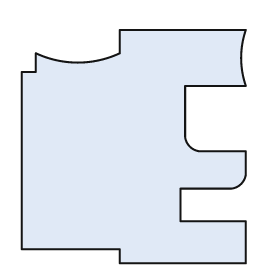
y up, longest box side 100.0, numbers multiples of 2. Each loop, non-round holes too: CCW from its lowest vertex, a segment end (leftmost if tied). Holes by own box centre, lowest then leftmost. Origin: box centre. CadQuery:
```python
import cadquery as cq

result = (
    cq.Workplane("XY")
    .moveTo(-6.0, -50.0)
    .lineTo(48.0, -50.0)
    .lineTo(48.0, -32.0)
    .lineTo(20.0, -32.0)
    .lineTo(20.0, -18.0)
    .lineTo(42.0, -18.0)
    .threePointArc((46.0, -16.0), (48.0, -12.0))
    .lineTo(48.0, -2.0)
    .lineTo(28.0, -2.0)
    .threePointArc((24.0, 0.0), (22.0, 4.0))
    .lineTo(22.0, 26.0)
    .lineTo(48.0, 26.0)
    .threePointArc((46.0, 38.0), (48.0, 50.0))
    .lineTo(-6.0, 50.0)
    .lineTo(-6.0, 40.0)
    .threePointArc((-24.0, 36.0), (-42.0, 40.0))
    .lineTo(-42.0, 32.0)
    .lineTo(-48.0, 32.0)
    .lineTo(-48.0, -44.0)
    .lineTo(-6.0, -44.0)
    .close()
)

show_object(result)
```